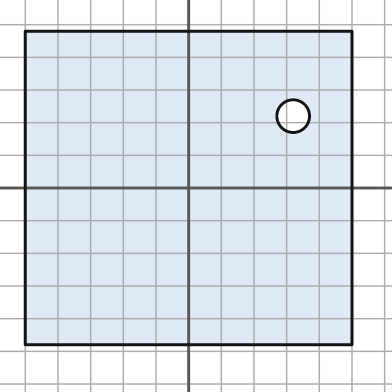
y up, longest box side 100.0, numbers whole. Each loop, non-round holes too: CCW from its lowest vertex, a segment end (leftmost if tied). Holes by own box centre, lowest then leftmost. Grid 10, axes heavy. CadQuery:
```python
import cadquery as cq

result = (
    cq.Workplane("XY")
    .moveTo(-50.0, -48.0)
    .lineTo(50.0, -48.0)
    .lineTo(50.0, 48.0)
    .lineTo(-50.0, 48.0)
    .close()
    .moveTo(32.0, 22.0)
    .circle(5.0)
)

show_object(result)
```